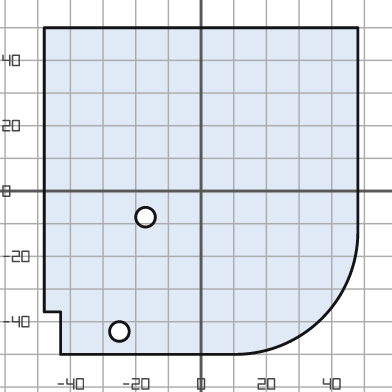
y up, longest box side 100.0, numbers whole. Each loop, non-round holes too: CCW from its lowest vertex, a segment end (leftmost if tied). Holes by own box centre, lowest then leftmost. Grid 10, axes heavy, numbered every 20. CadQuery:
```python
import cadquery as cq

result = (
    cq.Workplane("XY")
    .moveTo(-43.0, -50.0)
    .lineTo(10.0, -50.0)
    .threePointArc((37.0, -39.0), (48.0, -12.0))
    .lineTo(48.0, 50.0)
    .lineTo(-48.0, 50.0)
    .lineTo(-48.0, -37.0)
    .lineTo(-43.0, -37.0)
    .close()
    .moveTo(-25.0, -43.0)
    .circle(3.0)
    .moveTo(-17.0, -8.0)
    .circle(3.0)
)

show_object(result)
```